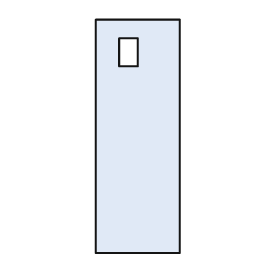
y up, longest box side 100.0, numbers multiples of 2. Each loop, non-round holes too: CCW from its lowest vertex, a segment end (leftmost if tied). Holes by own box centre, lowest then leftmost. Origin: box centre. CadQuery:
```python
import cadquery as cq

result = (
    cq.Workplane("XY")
    .moveTo(-18.0, -50.0)
    .lineTo(18.0, -50.0)
    .lineTo(18.0, 50.0)
    .lineTo(-18.0, 50.0)
    .close()
    .moveTo(-8.0, 30.0)
    .lineTo(0.0, 30.0)
    .lineTo(0.0, 42.0)
    .lineTo(-8.0, 42.0)
    .close()
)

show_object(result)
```